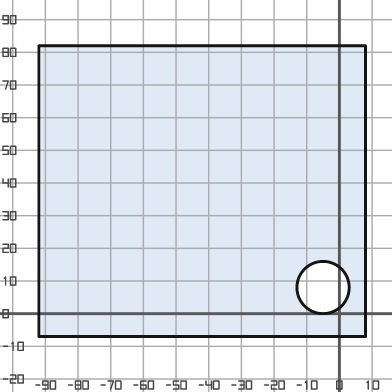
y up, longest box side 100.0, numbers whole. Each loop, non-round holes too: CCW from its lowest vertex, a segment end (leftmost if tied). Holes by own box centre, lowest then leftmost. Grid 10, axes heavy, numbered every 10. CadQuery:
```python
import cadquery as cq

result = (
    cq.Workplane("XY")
    .moveTo(-92.0, -7.0)
    .lineTo(8.0, -7.0)
    .lineTo(8.0, 82.0)
    .lineTo(-92.0, 82.0)
    .close()
    .moveTo(-5.0, 8.0)
    .circle(8.0)
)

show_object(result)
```